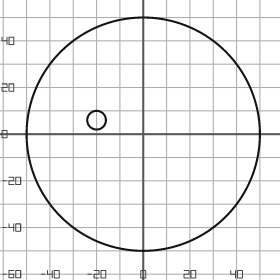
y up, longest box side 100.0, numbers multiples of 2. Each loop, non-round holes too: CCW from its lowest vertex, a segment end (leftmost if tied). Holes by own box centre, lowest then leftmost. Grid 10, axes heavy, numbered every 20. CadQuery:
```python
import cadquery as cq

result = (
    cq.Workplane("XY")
    .moveTo(0.0, 0.0)
    .circle(50.0)
    .moveTo(-20.0, 6.0)
    .circle(4.0)
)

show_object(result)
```